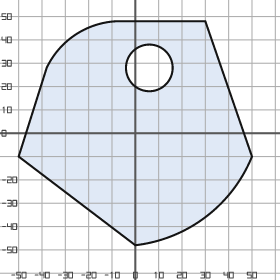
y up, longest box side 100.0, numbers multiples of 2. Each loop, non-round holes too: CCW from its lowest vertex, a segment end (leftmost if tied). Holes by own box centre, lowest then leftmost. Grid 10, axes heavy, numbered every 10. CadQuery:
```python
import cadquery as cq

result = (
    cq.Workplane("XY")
    .moveTo(0.0, -48.0)
    .threePointArc((30.0, -36.0), (50.0, -10.0))
    .lineTo(30.0, 48.0)
    .lineTo(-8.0, 48.0)
    .threePointArc((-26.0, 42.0), (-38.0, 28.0))
    .lineTo(-50.0, -10.0)
    .close()
    .moveTo(6.0, 28.0)
    .circle(10.0)
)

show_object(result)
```